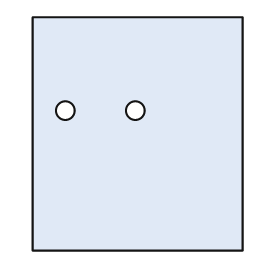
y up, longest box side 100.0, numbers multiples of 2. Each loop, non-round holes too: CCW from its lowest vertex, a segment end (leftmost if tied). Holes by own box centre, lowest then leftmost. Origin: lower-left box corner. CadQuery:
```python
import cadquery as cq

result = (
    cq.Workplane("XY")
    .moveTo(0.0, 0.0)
    .lineTo(90.0, 0.0)
    .lineTo(90.0, 100.0)
    .lineTo(0.0, 100.0)
    .close()
    .moveTo(14.0, 60.0)
    .circle(4.0)
    .moveTo(44.0, 60.0)
    .circle(4.0)
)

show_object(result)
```